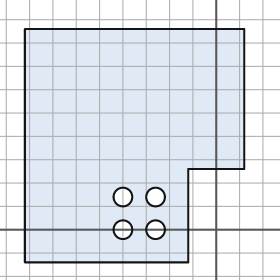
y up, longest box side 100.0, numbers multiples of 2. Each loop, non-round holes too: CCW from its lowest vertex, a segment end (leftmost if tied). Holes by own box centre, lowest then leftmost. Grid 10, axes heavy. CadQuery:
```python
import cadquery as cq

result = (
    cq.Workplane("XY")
    .moveTo(-82.0, -14.0)
    .lineTo(-12.0, -14.0)
    .lineTo(-12.0, 26.0)
    .lineTo(12.0, 26.0)
    .lineTo(12.0, 86.0)
    .lineTo(-82.0, 86.0)
    .close()
    .moveTo(-40.0, 0.0)
    .circle(4.0)
    .moveTo(-26.0, 0.0)
    .circle(4.0)
    .moveTo(-40.0, 14.0)
    .circle(4.0)
    .moveTo(-26.0, 14.0)
    .circle(4.0)
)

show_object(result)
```